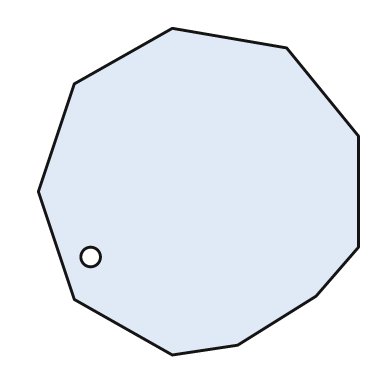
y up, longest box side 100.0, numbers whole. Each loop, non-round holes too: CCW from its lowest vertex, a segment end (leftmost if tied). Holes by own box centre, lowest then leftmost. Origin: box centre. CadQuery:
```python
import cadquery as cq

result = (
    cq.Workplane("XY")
    .moveTo(-8.0, -50.0)
    .lineTo(12.0, -47.0)
    .lineTo(36.0, -32.0)
    .lineTo(49.0, -17.0)
    .lineTo(49.0, 17.0)
    .lineTo(27.0, 44.0)
    .lineTo(-8.0, 50.0)
    .lineTo(-38.0, 33.0)
    .lineTo(-49.0, 0.0)
    .lineTo(-38.0, -33.0)
    .close()
    .moveTo(-33.0, -20.0)
    .circle(3.0)
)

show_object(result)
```